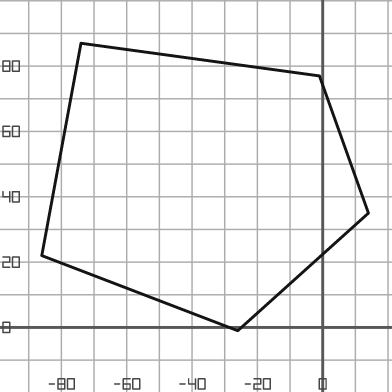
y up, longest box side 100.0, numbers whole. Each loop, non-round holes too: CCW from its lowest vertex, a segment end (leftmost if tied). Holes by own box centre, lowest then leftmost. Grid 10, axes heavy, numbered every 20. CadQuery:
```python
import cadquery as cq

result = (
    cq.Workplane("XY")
    .moveTo(-26.0, -1.0)
    .lineTo(14.0, 35.0)
    .lineTo(-1.0, 77.0)
    .lineTo(-74.0, 87.0)
    .lineTo(-86.0, 22.0)
    .close()
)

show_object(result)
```